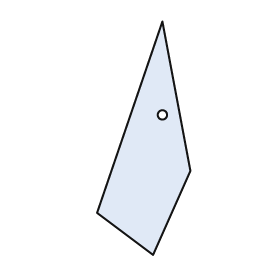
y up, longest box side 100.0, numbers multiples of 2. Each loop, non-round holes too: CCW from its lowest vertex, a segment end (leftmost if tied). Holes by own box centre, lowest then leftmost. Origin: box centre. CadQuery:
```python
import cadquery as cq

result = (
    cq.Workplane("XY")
    .moveTo(4.0, -50.0)
    .lineTo(20.0, -14.0)
    .lineTo(8.0, 50.0)
    .lineTo(-20.0, -32.0)
    .close()
    .moveTo(8.0, 10.0)
    .circle(2.0)
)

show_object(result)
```